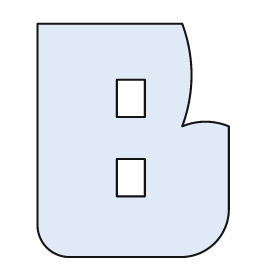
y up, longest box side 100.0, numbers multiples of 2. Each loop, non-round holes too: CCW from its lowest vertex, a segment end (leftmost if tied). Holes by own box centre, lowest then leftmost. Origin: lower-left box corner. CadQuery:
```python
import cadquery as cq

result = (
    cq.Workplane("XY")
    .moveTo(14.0, 0.0)
    .lineTo(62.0, 0.0)
    .threePointArc((76.0, 6.0), (82.0, 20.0))
    .lineTo(82.0, 56.0)
    .threePointArc((72.0, 58.0), (62.0, 56.0))
    .threePointArc((66.0, 78.0), (62.0, 100.0))
    .lineTo(0.0, 100.0)
    .lineTo(0.0, 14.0)
    .threePointArc((4.0, 4.0), (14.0, 0.0))
    .close()
    .moveTo(34.0, 26.0)
    .lineTo(46.0, 26.0)
    .lineTo(46.0, 42.0)
    .lineTo(34.0, 42.0)
    .close()
    .moveTo(34.0, 60.0)
    .lineTo(46.0, 60.0)
    .lineTo(46.0, 76.0)
    .lineTo(34.0, 76.0)
    .close()
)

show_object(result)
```